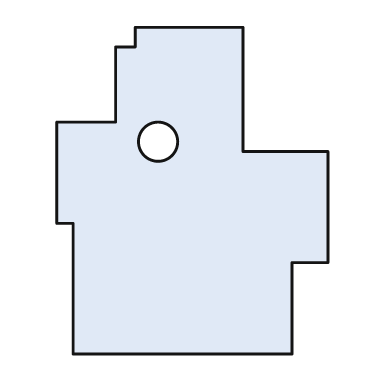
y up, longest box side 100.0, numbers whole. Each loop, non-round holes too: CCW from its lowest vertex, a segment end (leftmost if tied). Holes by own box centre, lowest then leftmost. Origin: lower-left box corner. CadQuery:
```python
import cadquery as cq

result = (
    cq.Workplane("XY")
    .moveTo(5.0, 0.0)
    .lineTo(72.0, 0.0)
    .lineTo(72.0, 28.0)
    .lineTo(83.0, 28.0)
    .lineTo(83.0, 62.0)
    .lineTo(57.0, 62.0)
    .lineTo(57.0, 100.0)
    .lineTo(24.0, 100.0)
    .lineTo(24.0, 94.0)
    .lineTo(18.0, 94.0)
    .lineTo(18.0, 71.0)
    .lineTo(0.0, 71.0)
    .lineTo(0.0, 40.0)
    .lineTo(5.0, 40.0)
    .close()
    .moveTo(31.0, 65.0)
    .circle(6.0)
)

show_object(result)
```